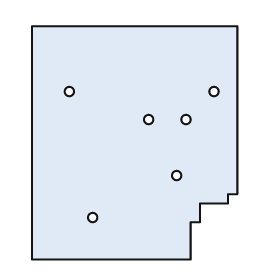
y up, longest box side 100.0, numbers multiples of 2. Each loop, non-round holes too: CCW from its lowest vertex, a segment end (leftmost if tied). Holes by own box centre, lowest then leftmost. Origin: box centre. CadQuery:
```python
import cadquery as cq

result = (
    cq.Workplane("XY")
    .moveTo(-44.0, -50.0)
    .lineTo(24.0, -50.0)
    .lineTo(24.0, -34.0)
    .lineTo(28.0, -34.0)
    .lineTo(28.0, -26.0)
    .lineTo(40.0, -26.0)
    .lineTo(40.0, -22.0)
    .lineTo(44.0, -22.0)
    .lineTo(44.0, 50.0)
    .lineTo(-44.0, 50.0)
    .close()
    .moveTo(-18.0, -32.0)
    .circle(2.0)
    .moveTo(18.0, -14.0)
    .circle(2.0)
    .moveTo(6.0, 10.0)
    .circle(2.0)
    .moveTo(22.0, 10.0)
    .circle(2.0)
    .moveTo(-28.0, 22.0)
    .circle(2.0)
    .moveTo(34.0, 22.0)
    .circle(2.0)
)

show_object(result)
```